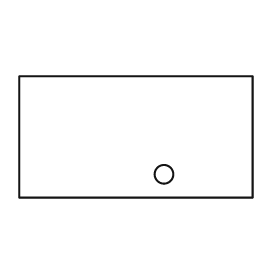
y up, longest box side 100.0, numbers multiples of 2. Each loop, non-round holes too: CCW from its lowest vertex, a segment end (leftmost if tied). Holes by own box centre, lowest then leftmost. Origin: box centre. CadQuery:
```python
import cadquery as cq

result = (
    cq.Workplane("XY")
    .moveTo(-50.0, -26.0)
    .lineTo(50.0, -26.0)
    .lineTo(50.0, 26.0)
    .lineTo(-50.0, 26.0)
    .close()
    .moveTo(12.0, -16.0)
    .circle(4.0)
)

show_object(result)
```